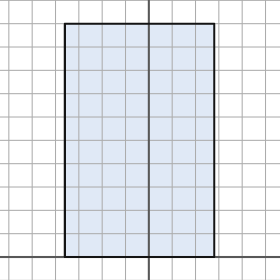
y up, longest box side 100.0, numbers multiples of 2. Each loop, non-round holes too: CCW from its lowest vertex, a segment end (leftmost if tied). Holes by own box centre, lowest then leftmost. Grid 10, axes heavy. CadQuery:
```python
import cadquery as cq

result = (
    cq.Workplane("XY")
    .moveTo(-36.0, 0.0)
    .lineTo(28.0, 0.0)
    .lineTo(28.0, 100.0)
    .lineTo(-36.0, 100.0)
    .close()
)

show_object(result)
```